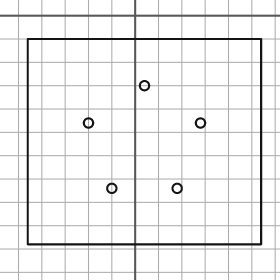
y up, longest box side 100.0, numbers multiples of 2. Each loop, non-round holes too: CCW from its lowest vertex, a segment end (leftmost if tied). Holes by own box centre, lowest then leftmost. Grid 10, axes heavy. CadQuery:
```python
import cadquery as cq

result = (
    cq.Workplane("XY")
    .moveTo(-46.0, -98.0)
    .lineTo(54.0, -98.0)
    .lineTo(54.0, -10.0)
    .lineTo(-46.0, -10.0)
    .close()
    .moveTo(-10.0, -74.0)
    .circle(2.0)
    .moveTo(18.0, -74.0)
    .circle(2.0)
    .moveTo(-20.0, -46.0)
    .circle(2.0)
    .moveTo(28.0, -46.0)
    .circle(2.0)
    .moveTo(4.0, -30.0)
    .circle(2.0)
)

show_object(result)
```